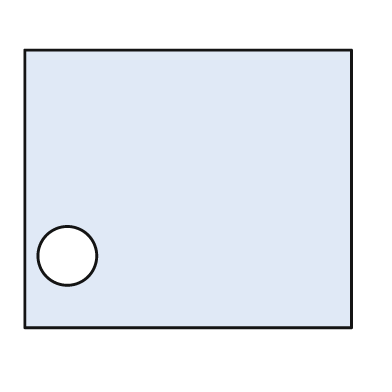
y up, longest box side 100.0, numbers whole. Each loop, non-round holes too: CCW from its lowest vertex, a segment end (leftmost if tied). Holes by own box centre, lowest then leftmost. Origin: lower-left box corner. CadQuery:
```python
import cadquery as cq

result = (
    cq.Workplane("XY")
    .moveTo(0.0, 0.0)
    .lineTo(100.0, 0.0)
    .lineTo(100.0, 85.0)
    .lineTo(0.0, 85.0)
    .close()
    .moveTo(13.0, 22.0)
    .circle(9.0)
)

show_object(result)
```